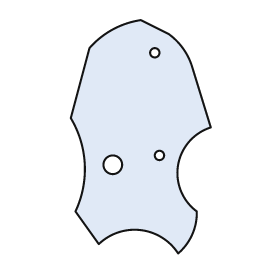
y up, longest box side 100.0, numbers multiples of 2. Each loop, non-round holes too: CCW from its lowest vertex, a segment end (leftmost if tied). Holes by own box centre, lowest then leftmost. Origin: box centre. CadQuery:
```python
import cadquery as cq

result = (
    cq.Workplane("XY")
    .moveTo(16.0, -50.0)
    .threePointArc((22.0, -42.0), (24.0, -32.0))
    .threePointArc((16.0, -12.0), (30.0, 4.0))
    .lineTo(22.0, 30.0)
    .threePointArc((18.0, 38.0), (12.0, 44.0))
    .lineTo(0.0, 50.0)
    .threePointArc((-12.0, 46.0), (-22.0, 38.0))
    .lineTo(-30.0, 8.0)
    .threePointArc((-24.0, -12.0), (-28.0, -32.0))
    .lineTo(-18.0, -46.0)
    .threePointArc((0.0, -40.0), (16.0, -50.0))
    .close()
    .moveTo(-12.0, -12.0)
    .circle(4.0)
    .moveTo(8.0, -8.0)
    .circle(2.0)
    .moveTo(6.0, 36.0)
    .circle(2.0)
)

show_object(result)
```